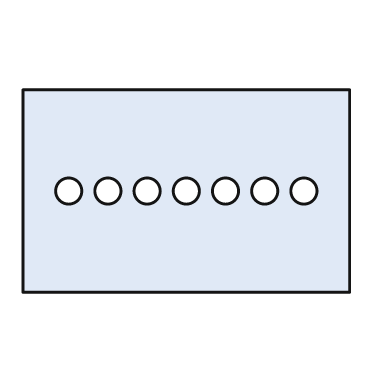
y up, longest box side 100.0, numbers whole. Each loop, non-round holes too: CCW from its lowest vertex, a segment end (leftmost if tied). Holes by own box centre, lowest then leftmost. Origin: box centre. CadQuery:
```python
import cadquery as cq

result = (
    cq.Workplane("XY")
    .moveTo(-50.0, -31.0)
    .lineTo(50.0, -31.0)
    .lineTo(50.0, 31.0)
    .lineTo(-50.0, 31.0)
    .close()
    .moveTo(-36.0, 0.0)
    .circle(4.0)
    .moveTo(-24.0, 0.0)
    .circle(4.0)
    .moveTo(-12.0, 0.0)
    .circle(4.0)
    .moveTo(0.0, 0.0)
    .circle(4.0)
    .moveTo(12.0, 0.0)
    .circle(4.0)
    .moveTo(24.0, 0.0)
    .circle(4.0)
    .moveTo(36.0, 0.0)
    .circle(4.0)
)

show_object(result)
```